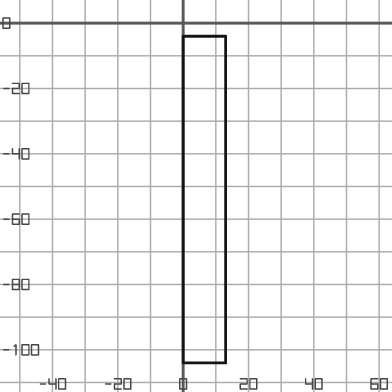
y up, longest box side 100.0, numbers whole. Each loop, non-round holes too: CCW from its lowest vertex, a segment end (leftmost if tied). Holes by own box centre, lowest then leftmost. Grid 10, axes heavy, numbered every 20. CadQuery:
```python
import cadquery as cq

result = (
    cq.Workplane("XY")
    .moveTo(0.0, -104.0)
    .lineTo(13.0, -104.0)
    .lineTo(13.0, -4.0)
    .lineTo(0.0, -4.0)
    .close()
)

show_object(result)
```